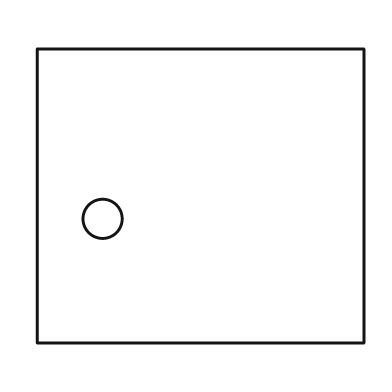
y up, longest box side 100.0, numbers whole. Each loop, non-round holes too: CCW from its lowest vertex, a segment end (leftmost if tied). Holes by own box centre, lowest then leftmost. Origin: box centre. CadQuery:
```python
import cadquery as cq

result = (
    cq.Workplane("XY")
    .moveTo(-50.0, -45.0)
    .lineTo(50.0, -45.0)
    .lineTo(50.0, 45.0)
    .lineTo(-50.0, 45.0)
    .close()
    .moveTo(-30.0, -7.0)
    .circle(6.0)
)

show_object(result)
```